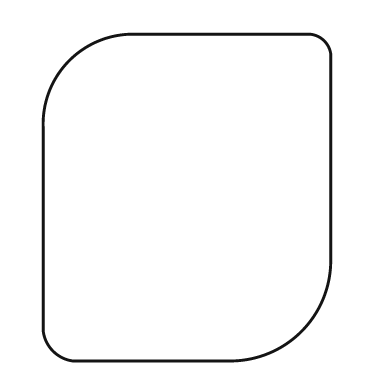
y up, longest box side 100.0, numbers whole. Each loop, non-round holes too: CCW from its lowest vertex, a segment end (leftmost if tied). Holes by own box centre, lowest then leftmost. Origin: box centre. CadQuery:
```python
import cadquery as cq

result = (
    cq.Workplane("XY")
    .moveTo(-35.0, -50.0)
    .lineTo(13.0, -50.0)
    .threePointArc((35.0, -41.0), (44.0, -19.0))
    .lineTo(44.0, 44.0)
    .threePointArc((42.0, 48.0), (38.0, 50.0))
    .lineTo(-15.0, 50.0)
    .threePointArc((-36.0, 42.0), (-44.0, 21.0))
    .lineTo(-44.0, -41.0)
    .threePointArc((-41.0, -47.0), (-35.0, -50.0))
    .close()
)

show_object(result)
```